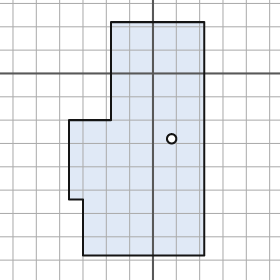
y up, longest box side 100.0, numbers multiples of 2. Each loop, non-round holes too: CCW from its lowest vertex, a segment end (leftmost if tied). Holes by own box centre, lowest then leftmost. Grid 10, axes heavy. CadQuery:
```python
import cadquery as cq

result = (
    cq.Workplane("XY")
    .moveTo(-30.0, -78.0)
    .lineTo(22.0, -78.0)
    .lineTo(22.0, 22.0)
    .lineTo(-18.0, 22.0)
    .lineTo(-18.0, -20.0)
    .lineTo(-36.0, -20.0)
    .lineTo(-36.0, -54.0)
    .lineTo(-30.0, -54.0)
    .close()
    .moveTo(8.0, -28.0)
    .circle(2.0)
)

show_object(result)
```